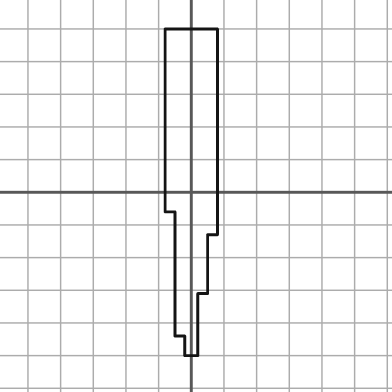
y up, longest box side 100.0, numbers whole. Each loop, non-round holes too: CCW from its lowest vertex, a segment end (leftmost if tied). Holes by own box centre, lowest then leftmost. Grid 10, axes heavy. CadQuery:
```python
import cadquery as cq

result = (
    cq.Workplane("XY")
    .moveTo(-2.0, -50.0)
    .lineTo(2.0, -50.0)
    .lineTo(2.0, -31.0)
    .lineTo(5.0, -31.0)
    .lineTo(5.0, -13.0)
    .lineTo(8.0, -13.0)
    .lineTo(8.0, 50.0)
    .lineTo(-8.0, 50.0)
    .lineTo(-8.0, -6.0)
    .lineTo(-5.0, -6.0)
    .lineTo(-5.0, -44.0)
    .lineTo(-2.0, -44.0)
    .close()
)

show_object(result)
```